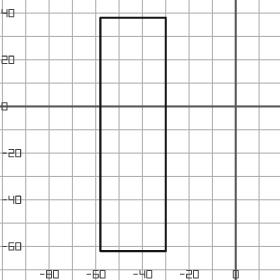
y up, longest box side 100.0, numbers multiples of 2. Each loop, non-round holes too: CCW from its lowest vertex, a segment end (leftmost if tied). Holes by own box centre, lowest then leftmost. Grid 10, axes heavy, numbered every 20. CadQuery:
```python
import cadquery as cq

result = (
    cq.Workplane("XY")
    .moveTo(-58.0, -62.0)
    .lineTo(-30.0, -62.0)
    .lineTo(-30.0, 38.0)
    .lineTo(-58.0, 38.0)
    .close()
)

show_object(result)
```